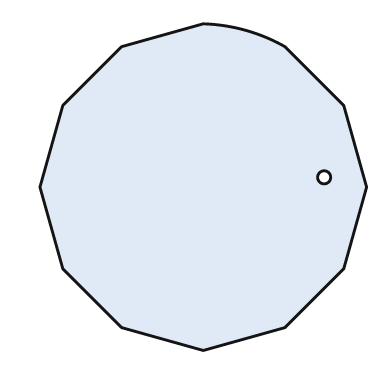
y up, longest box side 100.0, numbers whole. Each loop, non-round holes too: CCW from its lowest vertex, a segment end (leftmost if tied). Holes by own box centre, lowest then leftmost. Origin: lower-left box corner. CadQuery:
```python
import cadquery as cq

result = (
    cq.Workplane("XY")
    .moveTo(50.0, 0.0)
    .lineTo(75.0, 7.0)
    .lineTo(93.0, 25.0)
    .lineTo(100.0, 50.0)
    .lineTo(93.0, 75.0)
    .lineTo(75.0, 93.0)
    .threePointArc((63.0, 98.0), (50.0, 100.0))
    .lineTo(25.0, 93.0)
    .lineTo(7.0, 75.0)
    .lineTo(0.0, 50.0)
    .lineTo(7.0, 25.0)
    .lineTo(25.0, 7.0)
    .close()
    .moveTo(87.0, 53.0)
    .circle(2.0)
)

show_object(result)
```